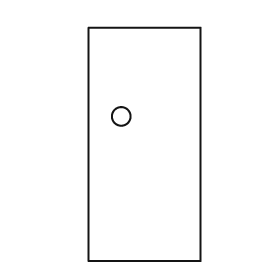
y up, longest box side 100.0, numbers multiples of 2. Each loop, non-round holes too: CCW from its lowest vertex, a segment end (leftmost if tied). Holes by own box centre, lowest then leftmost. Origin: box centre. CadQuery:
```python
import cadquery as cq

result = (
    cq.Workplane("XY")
    .moveTo(-24.0, -50.0)
    .lineTo(24.0, -50.0)
    .lineTo(24.0, 50.0)
    .lineTo(-24.0, 50.0)
    .close()
    .moveTo(-10.0, 12.0)
    .circle(4.0)
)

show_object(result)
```